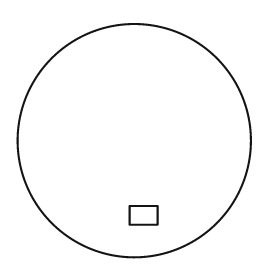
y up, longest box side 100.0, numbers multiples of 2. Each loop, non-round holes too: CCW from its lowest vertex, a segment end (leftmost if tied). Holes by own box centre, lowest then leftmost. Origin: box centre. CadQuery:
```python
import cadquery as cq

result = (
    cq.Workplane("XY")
    .moveTo(0.0, 0.0)
    .circle(50.0)
    .moveTo(-2.0, -36.0)
    .lineTo(10.0, -36.0)
    .lineTo(10.0, -28.0)
    .lineTo(-2.0, -28.0)
    .close()
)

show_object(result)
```